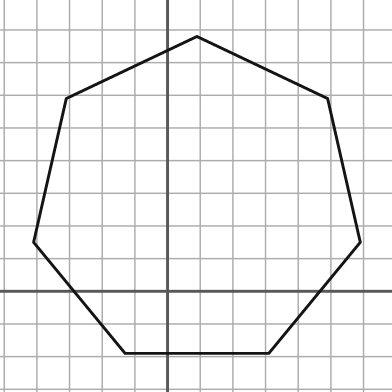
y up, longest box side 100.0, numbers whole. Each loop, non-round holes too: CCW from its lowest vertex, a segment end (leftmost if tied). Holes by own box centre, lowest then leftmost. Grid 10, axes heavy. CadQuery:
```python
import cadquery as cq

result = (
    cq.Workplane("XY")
    .moveTo(-13.0, -19.0)
    .lineTo(31.0, -19.0)
    .lineTo(59.0, 15.0)
    .lineTo(49.0, 59.0)
    .lineTo(9.0, 78.0)
    .lineTo(-31.0, 59.0)
    .lineTo(-41.0, 15.0)
    .close()
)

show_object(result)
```